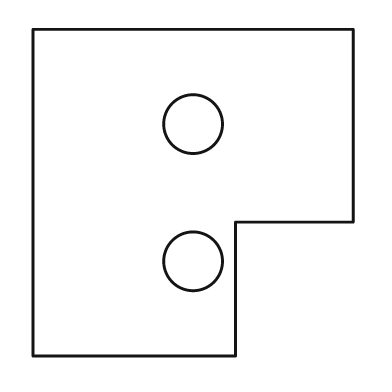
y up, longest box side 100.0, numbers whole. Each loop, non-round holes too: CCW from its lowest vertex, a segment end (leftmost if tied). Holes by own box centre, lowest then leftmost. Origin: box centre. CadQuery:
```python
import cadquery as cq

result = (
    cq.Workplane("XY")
    .moveTo(-49.0, -50.0)
    .lineTo(13.0, -50.0)
    .lineTo(13.0, -9.0)
    .lineTo(49.0, -9.0)
    .lineTo(49.0, 50.0)
    .lineTo(-49.0, 50.0)
    .close()
    .moveTo(0.0, -21.0)
    .circle(9.0)
    .moveTo(0.0, 21.0)
    .circle(9.0)
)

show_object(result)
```